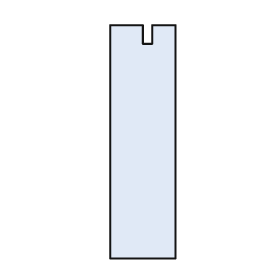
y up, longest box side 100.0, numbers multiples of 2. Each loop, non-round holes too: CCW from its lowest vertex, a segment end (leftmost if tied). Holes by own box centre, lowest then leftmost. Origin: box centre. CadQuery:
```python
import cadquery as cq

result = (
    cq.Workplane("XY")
    .moveTo(-14.0, -50.0)
    .lineTo(14.0, -50.0)
    .lineTo(14.0, 50.0)
    .lineTo(4.0, 50.0)
    .lineTo(4.0, 42.0)
    .lineTo(0.0, 42.0)
    .lineTo(0.0, 50.0)
    .lineTo(-14.0, 50.0)
    .close()
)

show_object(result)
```